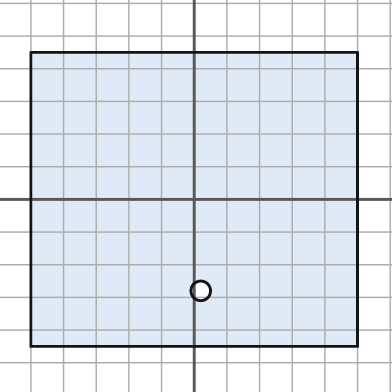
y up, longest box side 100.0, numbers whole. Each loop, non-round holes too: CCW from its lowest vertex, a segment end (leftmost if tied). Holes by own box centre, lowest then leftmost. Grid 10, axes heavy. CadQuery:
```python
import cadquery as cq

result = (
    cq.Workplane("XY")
    .moveTo(-50.0, -45.0)
    .lineTo(50.0, -45.0)
    .lineTo(50.0, 45.0)
    .lineTo(-50.0, 45.0)
    .close()
    .moveTo(2.0, -28.0)
    .circle(3.0)
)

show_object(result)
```